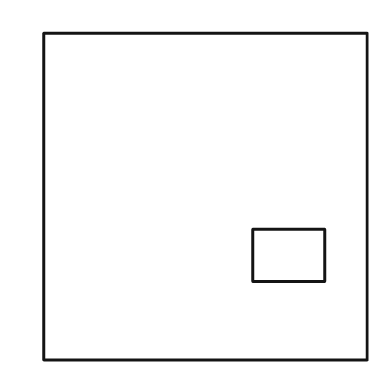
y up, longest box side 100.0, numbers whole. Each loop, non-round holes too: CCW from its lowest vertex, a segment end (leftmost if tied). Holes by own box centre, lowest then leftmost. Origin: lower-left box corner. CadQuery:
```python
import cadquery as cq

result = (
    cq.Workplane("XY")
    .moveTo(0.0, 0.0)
    .lineTo(99.0, 0.0)
    .lineTo(99.0, 100.0)
    .lineTo(0.0, 100.0)
    .close()
    .moveTo(64.0, 24.0)
    .lineTo(86.0, 24.0)
    .lineTo(86.0, 40.0)
    .lineTo(64.0, 40.0)
    .close()
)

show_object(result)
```